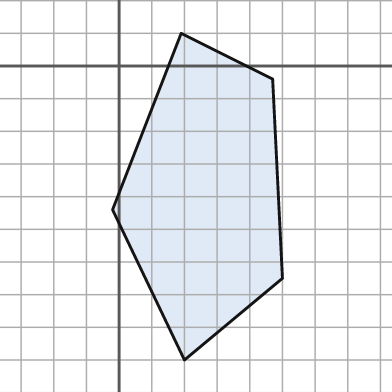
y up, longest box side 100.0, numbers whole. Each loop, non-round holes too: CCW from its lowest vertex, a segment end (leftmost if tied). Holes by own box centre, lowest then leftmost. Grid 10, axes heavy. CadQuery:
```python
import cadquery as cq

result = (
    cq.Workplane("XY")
    .moveTo(20.0, -90.0)
    .lineTo(50.0, -65.0)
    .lineTo(47.0, -4.0)
    .lineTo(19.0, 10.0)
    .lineTo(-2.0, -44.0)
    .close()
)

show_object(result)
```